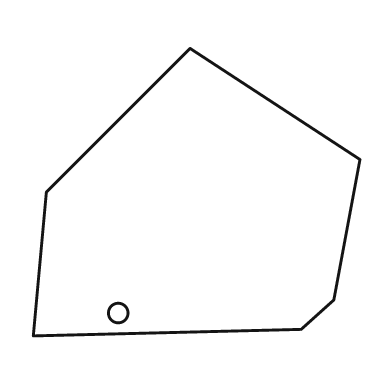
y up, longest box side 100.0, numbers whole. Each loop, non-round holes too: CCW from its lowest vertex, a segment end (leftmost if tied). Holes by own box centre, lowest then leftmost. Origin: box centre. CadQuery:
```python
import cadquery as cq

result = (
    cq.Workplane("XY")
    .moveTo(-50.0, -44.0)
    .lineTo(32.0, -42.0)
    .lineTo(42.0, -33.0)
    .lineTo(50.0, 10.0)
    .lineTo(-2.0, 44.0)
    .lineTo(-46.0, 0.0)
    .close()
    .moveTo(-24.0, -37.0)
    .circle(3.0)
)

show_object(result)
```